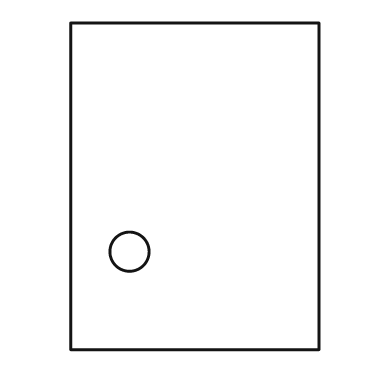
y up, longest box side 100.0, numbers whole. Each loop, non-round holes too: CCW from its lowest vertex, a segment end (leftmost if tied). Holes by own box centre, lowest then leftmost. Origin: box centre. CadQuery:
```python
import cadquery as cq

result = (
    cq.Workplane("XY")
    .moveTo(-38.0, -50.0)
    .lineTo(38.0, -50.0)
    .lineTo(38.0, 50.0)
    .lineTo(-38.0, 50.0)
    .close()
    .moveTo(-20.0, -20.0)
    .circle(6.0)
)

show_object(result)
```